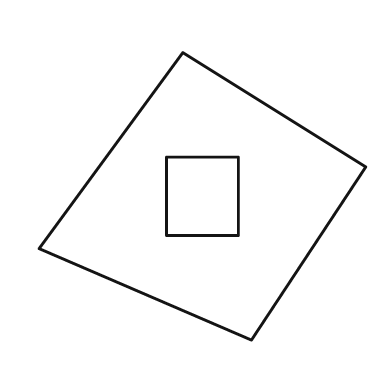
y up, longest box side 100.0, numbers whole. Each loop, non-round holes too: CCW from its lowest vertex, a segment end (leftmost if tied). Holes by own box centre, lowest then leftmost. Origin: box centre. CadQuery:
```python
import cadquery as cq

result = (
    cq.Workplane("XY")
    .moveTo(15.0, -44.0)
    .lineTo(50.0, 9.0)
    .lineTo(-6.0, 44.0)
    .lineTo(-50.0, -16.0)
    .close()
    .moveTo(-11.0, -12.0)
    .lineTo(11.0, -12.0)
    .lineTo(11.0, 12.0)
    .lineTo(-11.0, 12.0)
    .close()
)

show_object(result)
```